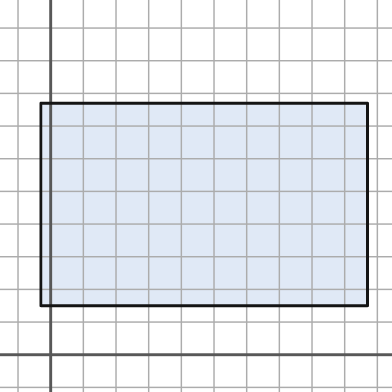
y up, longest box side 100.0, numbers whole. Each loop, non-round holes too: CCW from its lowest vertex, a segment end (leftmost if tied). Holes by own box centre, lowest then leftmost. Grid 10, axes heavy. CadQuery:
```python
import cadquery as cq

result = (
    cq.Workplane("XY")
    .moveTo(-3.0, 15.0)
    .lineTo(97.0, 15.0)
    .lineTo(97.0, 77.0)
    .lineTo(-3.0, 77.0)
    .close()
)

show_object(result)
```